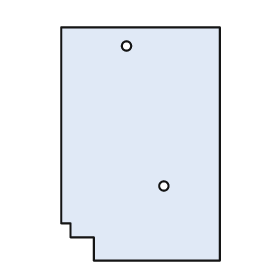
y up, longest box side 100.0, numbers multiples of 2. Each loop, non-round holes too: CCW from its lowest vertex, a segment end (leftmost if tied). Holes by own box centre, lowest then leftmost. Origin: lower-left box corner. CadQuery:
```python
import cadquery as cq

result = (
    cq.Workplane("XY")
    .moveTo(14.0, 0.0)
    .lineTo(68.0, 0.0)
    .lineTo(68.0, 100.0)
    .lineTo(0.0, 100.0)
    .lineTo(0.0, 16.0)
    .lineTo(4.0, 16.0)
    .lineTo(4.0, 10.0)
    .lineTo(14.0, 10.0)
    .close()
    .moveTo(44.0, 32.0)
    .circle(2.0)
    .moveTo(28.0, 92.0)
    .circle(2.0)
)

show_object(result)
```